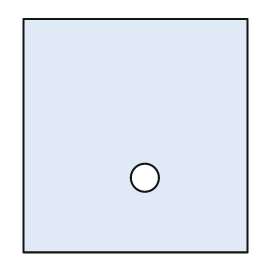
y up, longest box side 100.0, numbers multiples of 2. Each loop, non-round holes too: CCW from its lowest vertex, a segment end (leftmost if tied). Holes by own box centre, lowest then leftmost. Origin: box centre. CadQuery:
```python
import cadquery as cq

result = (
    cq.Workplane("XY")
    .moveTo(-48.0, -50.0)
    .lineTo(48.0, -50.0)
    .lineTo(48.0, 50.0)
    .lineTo(-48.0, 50.0)
    .close()
    .moveTo(4.0, -18.0)
    .circle(6.0)
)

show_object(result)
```